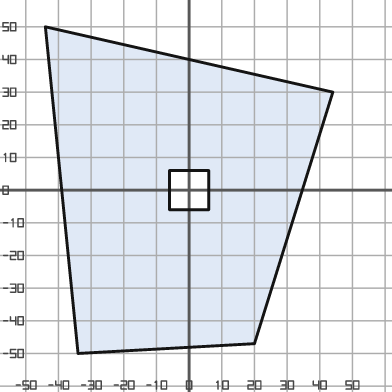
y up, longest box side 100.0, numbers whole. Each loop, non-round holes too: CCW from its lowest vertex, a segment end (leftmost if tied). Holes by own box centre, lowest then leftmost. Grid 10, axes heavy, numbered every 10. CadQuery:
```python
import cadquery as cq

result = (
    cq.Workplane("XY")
    .moveTo(-34.0, -50.0)
    .lineTo(20.0, -47.0)
    .lineTo(44.0, 30.0)
    .lineTo(-44.0, 50.0)
    .close()
    .moveTo(-6.0, -6.0)
    .lineTo(6.0, -6.0)
    .lineTo(6.0, 6.0)
    .lineTo(-6.0, 6.0)
    .close()
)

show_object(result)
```